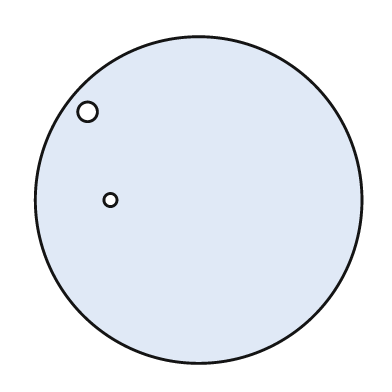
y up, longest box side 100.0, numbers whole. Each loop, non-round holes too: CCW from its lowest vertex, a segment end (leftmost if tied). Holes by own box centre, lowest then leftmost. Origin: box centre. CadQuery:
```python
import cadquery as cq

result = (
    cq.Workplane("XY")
    .moveTo(0.0, 0.0)
    .circle(50.0)
    .moveTo(-27.0, 0.0)
    .circle(2.0)
    .moveTo(-34.0, 27.0)
    .circle(3.0)
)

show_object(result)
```